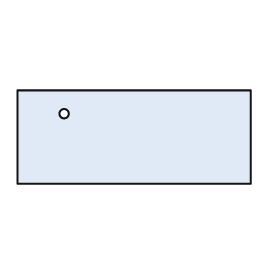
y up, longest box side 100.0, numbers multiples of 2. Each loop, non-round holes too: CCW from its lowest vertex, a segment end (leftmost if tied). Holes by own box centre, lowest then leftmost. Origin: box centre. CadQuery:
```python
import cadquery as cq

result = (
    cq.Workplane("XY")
    .moveTo(-50.0, -20.0)
    .lineTo(50.0, -20.0)
    .lineTo(50.0, 20.0)
    .lineTo(-50.0, 20.0)
    .close()
    .moveTo(-30.0, 10.0)
    .circle(2.0)
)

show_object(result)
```